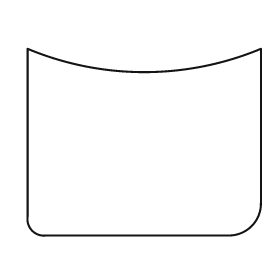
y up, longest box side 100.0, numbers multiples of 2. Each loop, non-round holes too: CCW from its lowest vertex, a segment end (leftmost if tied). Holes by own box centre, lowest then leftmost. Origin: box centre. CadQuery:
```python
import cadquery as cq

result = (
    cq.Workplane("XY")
    .moveTo(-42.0, -40.0)
    .lineTo(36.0, -40.0)
    .threePointArc((46.0, -36.0), (50.0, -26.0))
    .lineTo(50.0, 40.0)
    .threePointArc((0.0, 30.0), (-50.0, 40.0))
    .lineTo(-50.0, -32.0)
    .threePointArc((-48.0, -38.0), (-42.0, -40.0))
    .close()
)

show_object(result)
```